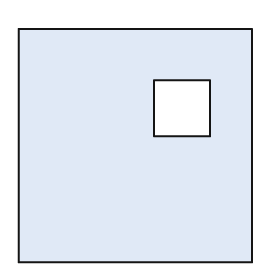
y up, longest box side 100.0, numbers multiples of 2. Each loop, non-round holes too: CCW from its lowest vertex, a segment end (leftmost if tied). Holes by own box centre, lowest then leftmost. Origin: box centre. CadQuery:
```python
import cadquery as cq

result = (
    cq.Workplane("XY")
    .moveTo(-50.0, -50.0)
    .lineTo(50.0, -50.0)
    .lineTo(50.0, 50.0)
    .lineTo(-50.0, 50.0)
    .close()
    .moveTo(8.0, 4.0)
    .lineTo(32.0, 4.0)
    .lineTo(32.0, 28.0)
    .lineTo(8.0, 28.0)
    .close()
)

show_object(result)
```